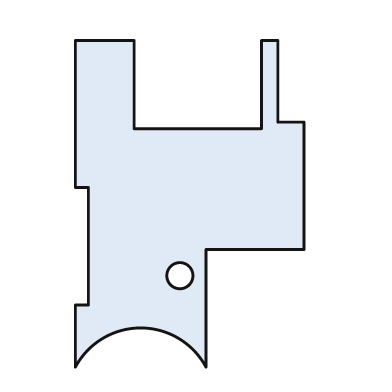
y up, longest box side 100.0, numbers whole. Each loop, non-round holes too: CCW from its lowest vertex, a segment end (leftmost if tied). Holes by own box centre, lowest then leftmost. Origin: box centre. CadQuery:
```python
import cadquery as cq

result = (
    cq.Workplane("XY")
    .moveTo(-35.0, -50.0)
    .threePointArc((-15.0, -38.0), (5.0, -50.0))
    .lineTo(5.0, -14.0)
    .lineTo(35.0, -14.0)
    .lineTo(35.0, 25.0)
    .lineTo(27.0, 25.0)
    .lineTo(27.0, 50.0)
    .lineTo(22.0, 50.0)
    .lineTo(22.0, 23.0)
    .lineTo(-17.0, 23.0)
    .lineTo(-17.0, 50.0)
    .lineTo(-35.0, 50.0)
    .lineTo(-35.0, 5.0)
    .lineTo(-31.0, 5.0)
    .lineTo(-31.0, -31.0)
    .lineTo(-35.0, -31.0)
    .close()
    .moveTo(-3.0, -22.0)
    .circle(4.0)
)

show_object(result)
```